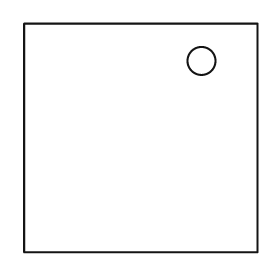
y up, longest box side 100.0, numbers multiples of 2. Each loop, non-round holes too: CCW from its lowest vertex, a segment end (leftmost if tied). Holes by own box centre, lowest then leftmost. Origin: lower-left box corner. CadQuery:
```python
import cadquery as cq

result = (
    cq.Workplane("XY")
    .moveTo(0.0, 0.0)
    .lineTo(100.0, 0.0)
    .lineTo(100.0, 98.0)
    .lineTo(0.0, 98.0)
    .close()
    .moveTo(76.0, 82.0)
    .circle(6.0)
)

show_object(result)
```